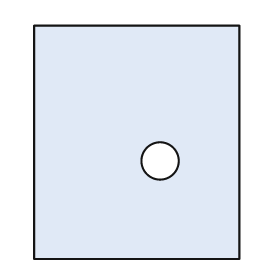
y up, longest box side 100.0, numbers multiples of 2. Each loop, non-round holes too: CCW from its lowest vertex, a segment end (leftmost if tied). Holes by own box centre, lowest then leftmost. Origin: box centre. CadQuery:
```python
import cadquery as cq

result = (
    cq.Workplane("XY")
    .moveTo(-44.0, -50.0)
    .lineTo(44.0, -50.0)
    .lineTo(44.0, 50.0)
    .lineTo(-44.0, 50.0)
    .close()
    .moveTo(10.0, -8.0)
    .circle(8.0)
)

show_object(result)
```